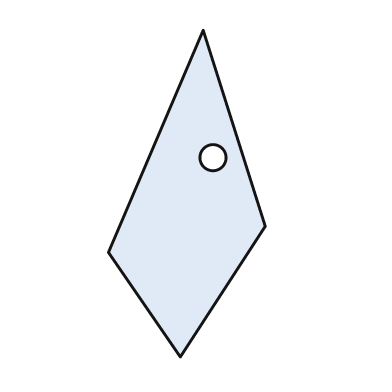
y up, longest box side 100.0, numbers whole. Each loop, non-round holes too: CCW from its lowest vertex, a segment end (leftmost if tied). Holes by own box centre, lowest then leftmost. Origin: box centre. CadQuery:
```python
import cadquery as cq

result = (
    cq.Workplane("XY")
    .moveTo(-2.0, -50.0)
    .lineTo(24.0, -10.0)
    .lineTo(5.0, 50.0)
    .lineTo(-24.0, -18.0)
    .close()
    .moveTo(8.0, 11.0)
    .circle(4.0)
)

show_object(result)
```